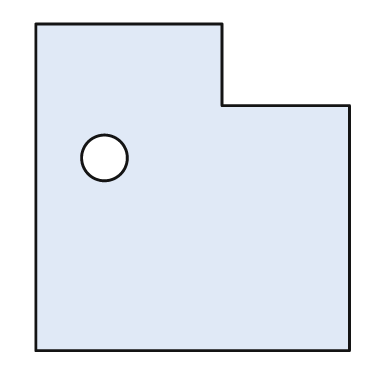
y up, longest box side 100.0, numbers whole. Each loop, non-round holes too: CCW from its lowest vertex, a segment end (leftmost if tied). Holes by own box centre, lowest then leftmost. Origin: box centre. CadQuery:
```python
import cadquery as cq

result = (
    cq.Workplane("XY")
    .moveTo(-48.0, -50.0)
    .lineTo(48.0, -50.0)
    .lineTo(48.0, 25.0)
    .lineTo(9.0, 25.0)
    .lineTo(9.0, 50.0)
    .lineTo(-48.0, 50.0)
    .close()
    .moveTo(-27.0, 9.0)
    .circle(7.0)
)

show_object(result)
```